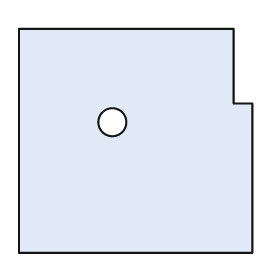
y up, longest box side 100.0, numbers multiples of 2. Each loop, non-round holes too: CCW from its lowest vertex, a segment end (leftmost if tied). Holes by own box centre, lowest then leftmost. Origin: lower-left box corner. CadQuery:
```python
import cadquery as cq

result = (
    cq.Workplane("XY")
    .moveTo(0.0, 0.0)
    .lineTo(100.0, 0.0)
    .lineTo(100.0, 64.0)
    .lineTo(92.0, 64.0)
    .lineTo(92.0, 96.0)
    .lineTo(0.0, 96.0)
    .close()
    .moveTo(40.0, 56.0)
    .circle(6.0)
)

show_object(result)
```